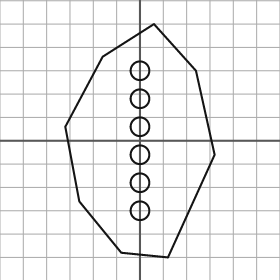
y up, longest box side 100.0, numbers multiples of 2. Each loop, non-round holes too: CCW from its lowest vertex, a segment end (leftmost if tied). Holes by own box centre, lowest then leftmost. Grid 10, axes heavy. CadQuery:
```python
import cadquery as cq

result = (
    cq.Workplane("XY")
    .moveTo(12.0, -50.0)
    .lineTo(32.0, -6.0)
    .lineTo(24.0, 30.0)
    .lineTo(6.0, 50.0)
    .lineTo(-16.0, 36.0)
    .lineTo(-32.0, 6.0)
    .lineTo(-26.0, -26.0)
    .lineTo(-8.0, -48.0)
    .close()
    .moveTo(0.0, -30.0)
    .circle(4.0)
    .moveTo(0.0, -18.0)
    .circle(4.0)
    .moveTo(0.0, -6.0)
    .circle(4.0)
    .moveTo(0.0, 6.0)
    .circle(4.0)
    .moveTo(0.0, 18.0)
    .circle(4.0)
    .moveTo(0.0, 30.0)
    .circle(4.0)
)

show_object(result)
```